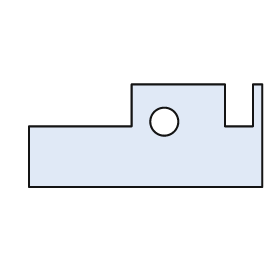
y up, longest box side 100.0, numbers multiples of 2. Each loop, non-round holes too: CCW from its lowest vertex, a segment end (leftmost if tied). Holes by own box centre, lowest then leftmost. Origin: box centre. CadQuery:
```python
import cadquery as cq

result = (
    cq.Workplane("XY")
    .moveTo(-50.0, -22.0)
    .lineTo(50.0, -22.0)
    .lineTo(50.0, 22.0)
    .lineTo(46.0, 22.0)
    .lineTo(46.0, 4.0)
    .lineTo(34.0, 4.0)
    .lineTo(34.0, 22.0)
    .lineTo(-6.0, 22.0)
    .lineTo(-6.0, 4.0)
    .lineTo(-50.0, 4.0)
    .close()
    .moveTo(8.0, 6.0)
    .circle(6.0)
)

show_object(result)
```